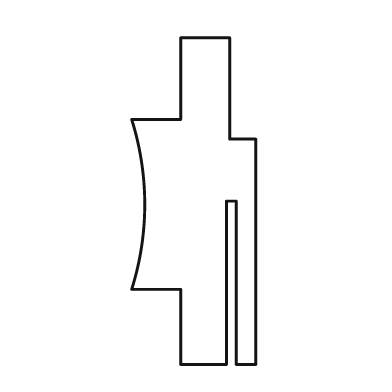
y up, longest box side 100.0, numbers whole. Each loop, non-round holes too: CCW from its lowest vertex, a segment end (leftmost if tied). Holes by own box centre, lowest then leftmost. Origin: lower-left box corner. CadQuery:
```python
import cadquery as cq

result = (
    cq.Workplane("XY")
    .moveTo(15.0, 0.0)
    .lineTo(29.0, 0.0)
    .lineTo(29.0, 50.0)
    .lineTo(32.0, 50.0)
    .lineTo(32.0, 0.0)
    .lineTo(38.0, 0.0)
    .lineTo(38.0, 69.0)
    .lineTo(30.0, 69.0)
    .lineTo(30.0, 100.0)
    .lineTo(15.0, 100.0)
    .lineTo(15.0, 75.0)
    .lineTo(0.0, 75.0)
    .threePointArc((4.0, 49.0), (0.0, 23.0))
    .lineTo(15.0, 23.0)
    .close()
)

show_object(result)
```